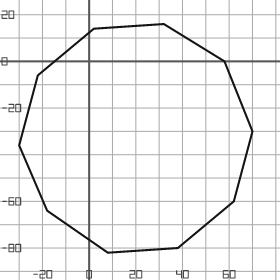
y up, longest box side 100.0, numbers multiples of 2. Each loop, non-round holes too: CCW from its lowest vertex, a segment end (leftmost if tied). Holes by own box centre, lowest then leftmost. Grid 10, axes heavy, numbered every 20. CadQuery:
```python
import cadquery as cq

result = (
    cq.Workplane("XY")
    .moveTo(8.0, -82.0)
    .lineTo(38.0, -80.0)
    .lineTo(62.0, -60.0)
    .lineTo(70.0, -30.0)
    .lineTo(58.0, 0.0)
    .lineTo(32.0, 16.0)
    .lineTo(2.0, 14.0)
    .lineTo(-22.0, -6.0)
    .lineTo(-30.0, -36.0)
    .lineTo(-18.0, -64.0)
    .close()
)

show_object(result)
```